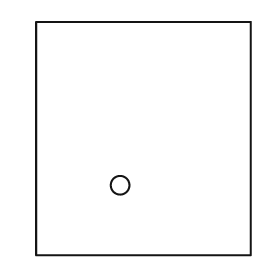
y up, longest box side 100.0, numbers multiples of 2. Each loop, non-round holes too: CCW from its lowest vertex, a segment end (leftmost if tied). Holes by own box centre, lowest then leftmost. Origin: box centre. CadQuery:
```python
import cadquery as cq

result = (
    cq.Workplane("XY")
    .moveTo(-46.0, -50.0)
    .lineTo(46.0, -50.0)
    .lineTo(46.0, 50.0)
    .lineTo(-46.0, 50.0)
    .close()
    .moveTo(-10.0, -20.0)
    .circle(4.0)
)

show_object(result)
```